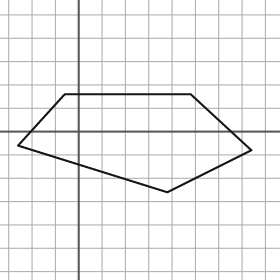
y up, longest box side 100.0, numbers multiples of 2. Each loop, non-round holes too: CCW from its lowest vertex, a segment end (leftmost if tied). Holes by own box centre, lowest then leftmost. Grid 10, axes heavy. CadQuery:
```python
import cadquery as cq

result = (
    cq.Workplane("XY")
    .moveTo(38.0, -26.0)
    .lineTo(74.0, -8.0)
    .lineTo(48.0, 16.0)
    .lineTo(-6.0, 16.0)
    .lineTo(-26.0, -6.0)
    .close()
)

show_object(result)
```